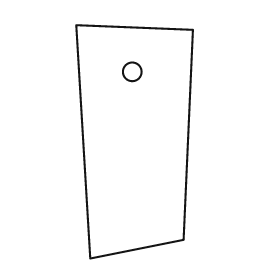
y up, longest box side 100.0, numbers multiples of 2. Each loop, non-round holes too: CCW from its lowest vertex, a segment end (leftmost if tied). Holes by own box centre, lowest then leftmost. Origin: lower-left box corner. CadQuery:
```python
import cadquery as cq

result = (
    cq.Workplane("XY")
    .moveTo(6.0, 0.0)
    .lineTo(46.0, 8.0)
    .lineTo(50.0, 98.0)
    .lineTo(0.0, 100.0)
    .close()
    .moveTo(24.0, 80.0)
    .circle(4.0)
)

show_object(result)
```